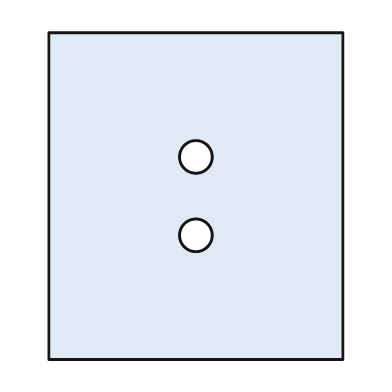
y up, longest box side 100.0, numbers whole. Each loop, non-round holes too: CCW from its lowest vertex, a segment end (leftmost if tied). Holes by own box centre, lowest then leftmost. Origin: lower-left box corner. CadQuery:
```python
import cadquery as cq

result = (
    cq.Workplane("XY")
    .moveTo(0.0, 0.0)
    .lineTo(90.0, 0.0)
    .lineTo(90.0, 100.0)
    .lineTo(0.0, 100.0)
    .close()
    .moveTo(45.0, 38.0)
    .circle(5.0)
    .moveTo(45.0, 62.0)
    .circle(5.0)
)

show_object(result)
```